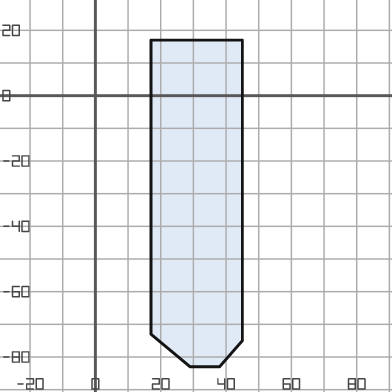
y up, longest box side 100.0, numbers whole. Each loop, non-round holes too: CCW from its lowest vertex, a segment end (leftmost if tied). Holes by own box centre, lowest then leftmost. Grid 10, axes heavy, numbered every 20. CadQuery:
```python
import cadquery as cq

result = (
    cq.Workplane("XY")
    .moveTo(29.0, -83.0)
    .lineTo(38.0, -83.0)
    .lineTo(45.0, -75.0)
    .lineTo(45.0, 17.0)
    .lineTo(17.0, 17.0)
    .lineTo(17.0, -73.0)
    .close()
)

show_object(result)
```